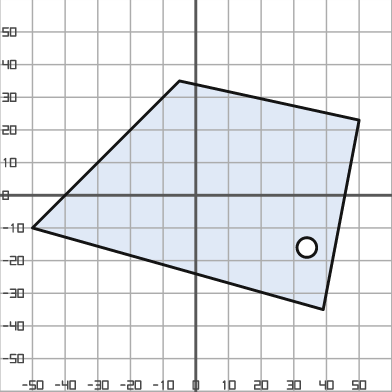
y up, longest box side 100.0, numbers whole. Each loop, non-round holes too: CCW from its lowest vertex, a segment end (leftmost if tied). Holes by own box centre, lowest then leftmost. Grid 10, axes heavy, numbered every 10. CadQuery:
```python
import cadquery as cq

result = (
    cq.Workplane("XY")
    .moveTo(39.0, -35.0)
    .lineTo(50.0, 23.0)
    .lineTo(-5.0, 35.0)
    .lineTo(-50.0, -10.0)
    .close()
    .moveTo(34.0, -16.0)
    .circle(3.0)
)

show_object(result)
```